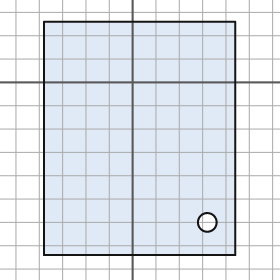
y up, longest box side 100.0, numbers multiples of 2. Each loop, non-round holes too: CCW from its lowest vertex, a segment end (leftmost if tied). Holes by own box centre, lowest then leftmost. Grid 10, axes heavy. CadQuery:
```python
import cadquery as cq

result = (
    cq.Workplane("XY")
    .moveTo(-38.0, -74.0)
    .lineTo(44.0, -74.0)
    .lineTo(44.0, 26.0)
    .lineTo(-38.0, 26.0)
    .close()
    .moveTo(32.0, -60.0)
    .circle(4.0)
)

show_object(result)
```